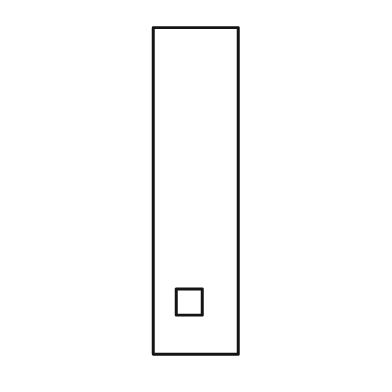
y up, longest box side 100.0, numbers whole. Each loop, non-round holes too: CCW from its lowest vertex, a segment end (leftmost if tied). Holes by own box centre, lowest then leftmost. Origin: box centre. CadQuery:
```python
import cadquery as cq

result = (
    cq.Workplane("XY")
    .moveTo(-13.0, -50.0)
    .lineTo(13.0, -50.0)
    .lineTo(13.0, 50.0)
    .lineTo(-13.0, 50.0)
    .close()
    .moveTo(-6.0, -38.0)
    .lineTo(2.0, -38.0)
    .lineTo(2.0, -30.0)
    .lineTo(-6.0, -30.0)
    .close()
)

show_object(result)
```